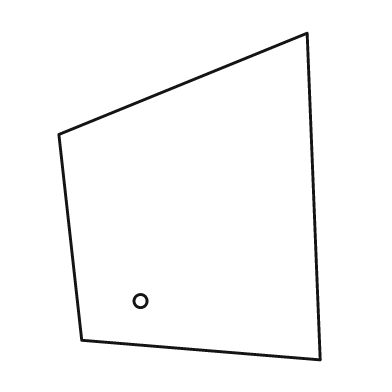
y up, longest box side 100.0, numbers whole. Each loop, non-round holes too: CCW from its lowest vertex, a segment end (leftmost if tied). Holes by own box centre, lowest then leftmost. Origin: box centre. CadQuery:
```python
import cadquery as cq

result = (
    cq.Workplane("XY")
    .moveTo(40.0, -50.0)
    .lineTo(36.0, 50.0)
    .lineTo(-40.0, 19.0)
    .lineTo(-33.0, -44.0)
    .close()
    .moveTo(-15.0, -32.0)
    .circle(2.0)
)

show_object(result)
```